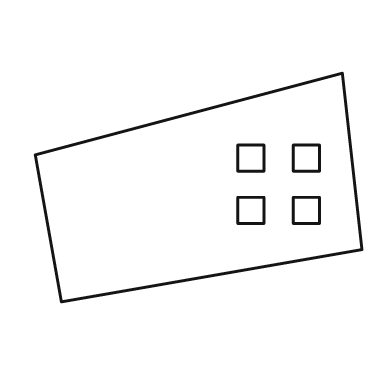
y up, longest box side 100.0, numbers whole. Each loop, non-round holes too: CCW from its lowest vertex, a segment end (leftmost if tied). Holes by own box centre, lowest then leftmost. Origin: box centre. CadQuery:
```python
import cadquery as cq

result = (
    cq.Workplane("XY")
    .moveTo(-42.0, -35.0)
    .lineTo(50.0, -19.0)
    .lineTo(44.0, 35.0)
    .lineTo(-50.0, 10.0)
    .close()
    .moveTo(12.0, -11.0)
    .lineTo(20.0, -11.0)
    .lineTo(20.0, -3.0)
    .lineTo(12.0, -3.0)
    .close()
    .moveTo(29.0, -11.0)
    .lineTo(37.0, -11.0)
    .lineTo(37.0, -3.0)
    .lineTo(29.0, -3.0)
    .close()
    .moveTo(12.0, 5.0)
    .lineTo(20.0, 5.0)
    .lineTo(20.0, 13.0)
    .lineTo(12.0, 13.0)
    .close()
    .moveTo(29.0, 5.0)
    .lineTo(37.0, 5.0)
    .lineTo(37.0, 13.0)
    .lineTo(29.0, 13.0)
    .close()
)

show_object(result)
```